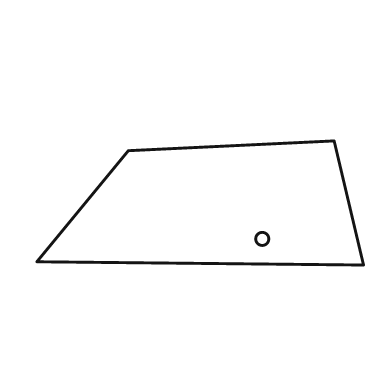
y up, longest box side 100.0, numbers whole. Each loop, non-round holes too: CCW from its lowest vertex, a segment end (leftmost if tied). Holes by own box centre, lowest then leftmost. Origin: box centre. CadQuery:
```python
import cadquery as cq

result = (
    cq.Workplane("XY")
    .moveTo(50.0, -19.0)
    .lineTo(41.0, 19.0)
    .lineTo(-22.0, 16.0)
    .lineTo(-50.0, -18.0)
    .close()
    .moveTo(19.0, -11.0)
    .circle(2.0)
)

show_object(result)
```